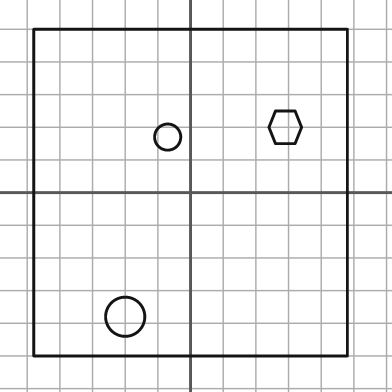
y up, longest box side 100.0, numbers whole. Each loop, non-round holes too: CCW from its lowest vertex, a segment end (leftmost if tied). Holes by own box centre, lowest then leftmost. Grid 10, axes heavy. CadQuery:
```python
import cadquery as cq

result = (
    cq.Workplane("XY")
    .moveTo(-48.0, -50.0)
    .lineTo(48.0, -50.0)
    .lineTo(48.0, 50.0)
    .lineTo(-48.0, 50.0)
    .close()
    .moveTo(-20.0, -38.0)
    .circle(6.0)
    .moveTo(-7.0, 17.0)
    .circle(4.0)
    .moveTo(26.0, 15.0)
    .lineTo(32.0, 15.0)
    .lineTo(34.0, 20.0)
    .lineTo(32.0, 25.0)
    .lineTo(26.0, 25.0)
    .lineTo(24.0, 20.0)
    .close()
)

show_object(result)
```